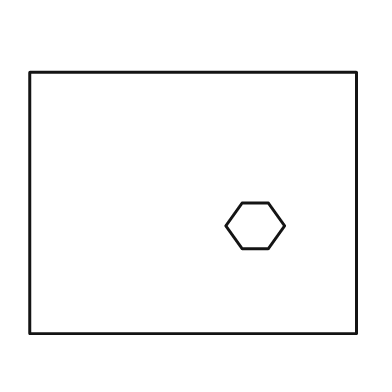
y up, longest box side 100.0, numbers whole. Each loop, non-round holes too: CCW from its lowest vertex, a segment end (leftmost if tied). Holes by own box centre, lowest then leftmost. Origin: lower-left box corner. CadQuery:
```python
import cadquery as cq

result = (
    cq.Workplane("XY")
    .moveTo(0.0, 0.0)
    .lineTo(100.0, 0.0)
    .lineTo(100.0, 80.0)
    .lineTo(0.0, 80.0)
    .close()
    .moveTo(65.0, 26.0)
    .lineTo(73.0, 26.0)
    .lineTo(78.0, 33.0)
    .lineTo(73.0, 40.0)
    .lineTo(65.0, 40.0)
    .lineTo(60.0, 33.0)
    .close()
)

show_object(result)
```